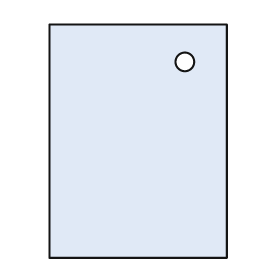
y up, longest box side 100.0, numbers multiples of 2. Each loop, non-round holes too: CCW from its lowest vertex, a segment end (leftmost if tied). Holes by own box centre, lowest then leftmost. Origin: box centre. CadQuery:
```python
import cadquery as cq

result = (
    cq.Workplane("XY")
    .moveTo(-38.0, -50.0)
    .lineTo(38.0, -50.0)
    .lineTo(38.0, 50.0)
    .lineTo(-38.0, 50.0)
    .close()
    .moveTo(20.0, 34.0)
    .circle(4.0)
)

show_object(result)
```